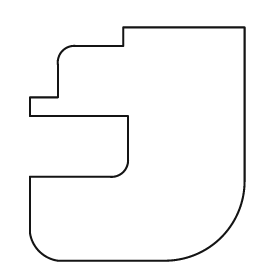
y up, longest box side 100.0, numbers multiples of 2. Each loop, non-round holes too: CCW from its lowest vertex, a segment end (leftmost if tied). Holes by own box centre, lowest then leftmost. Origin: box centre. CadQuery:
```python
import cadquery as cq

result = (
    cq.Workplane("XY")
    .moveTo(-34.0, -50.0)
    .lineTo(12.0, -50.0)
    .threePointArc((36.0, -40.0), (46.0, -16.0))
    .lineTo(46.0, 50.0)
    .lineTo(-6.0, 50.0)
    .lineTo(-6.0, 42.0)
    .lineTo(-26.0, 42.0)
    .threePointArc((-32.0, 40.0), (-34.0, 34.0))
    .lineTo(-34.0, 20.0)
    .lineTo(-46.0, 20.0)
    .lineTo(-46.0, 12.0)
    .lineTo(-4.0, 12.0)
    .lineTo(-4.0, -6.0)
    .threePointArc((-6.0, -12.0), (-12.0, -14.0))
    .lineTo(-46.0, -14.0)
    .lineTo(-46.0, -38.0)
    .threePointArc((-42.0, -46.0), (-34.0, -50.0))
    .close()
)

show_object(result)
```